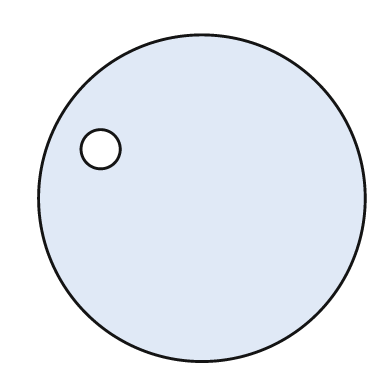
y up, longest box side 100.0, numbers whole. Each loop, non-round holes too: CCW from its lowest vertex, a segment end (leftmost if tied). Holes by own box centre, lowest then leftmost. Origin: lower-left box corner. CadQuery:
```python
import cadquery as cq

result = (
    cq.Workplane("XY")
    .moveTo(50.0, 50.0)
    .circle(50.0)
    .moveTo(19.0, 65.0)
    .circle(6.0)
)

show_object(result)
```